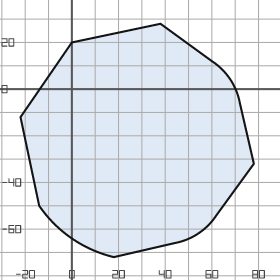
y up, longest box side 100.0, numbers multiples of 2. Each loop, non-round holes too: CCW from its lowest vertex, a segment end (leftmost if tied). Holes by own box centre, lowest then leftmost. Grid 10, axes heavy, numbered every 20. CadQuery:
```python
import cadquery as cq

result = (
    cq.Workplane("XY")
    .moveTo(18.0, -72.0)
    .lineTo(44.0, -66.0)
    .threePointArc((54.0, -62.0), (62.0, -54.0))
    .lineTo(78.0, -32.0)
    .lineTo(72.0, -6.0)
    .threePointArc((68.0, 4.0), (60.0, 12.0))
    .lineTo(38.0, 28.0)
    .lineTo(0.0, 20.0)
    .lineTo(-22.0, -12.0)
    .lineTo(-14.0, -50.0)
    .threePointArc((0.0, -64.0), (18.0, -72.0))
    .close()
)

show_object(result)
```